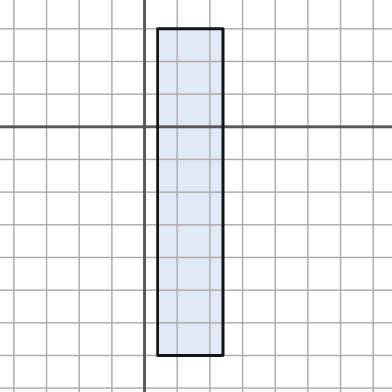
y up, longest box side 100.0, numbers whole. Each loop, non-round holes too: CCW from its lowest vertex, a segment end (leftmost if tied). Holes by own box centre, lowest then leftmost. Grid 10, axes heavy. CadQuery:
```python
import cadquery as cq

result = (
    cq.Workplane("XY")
    .moveTo(4.0, -70.0)
    .lineTo(24.0, -70.0)
    .lineTo(24.0, 30.0)
    .lineTo(4.0, 30.0)
    .close()
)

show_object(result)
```